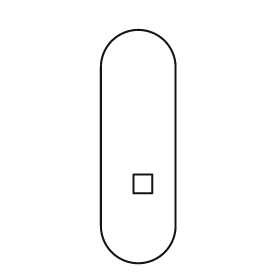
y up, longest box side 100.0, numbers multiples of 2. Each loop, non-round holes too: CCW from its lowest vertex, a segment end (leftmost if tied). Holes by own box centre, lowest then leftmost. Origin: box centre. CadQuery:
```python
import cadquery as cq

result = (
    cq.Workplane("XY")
    .moveTo(-16.0, -34.0)
    .threePointArc((0.0, -50.0), (16.0, -34.0))
    .lineTo(16.0, 34.0)
    .threePointArc((0.0, 50.0), (-16.0, 34.0))
    .close()
    .moveTo(-2.0, -20.0)
    .lineTo(6.0, -20.0)
    .lineTo(6.0, -12.0)
    .lineTo(-2.0, -12.0)
    .close()
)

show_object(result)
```